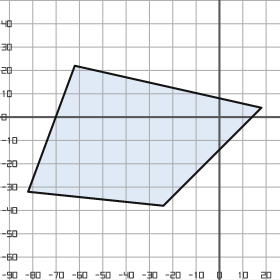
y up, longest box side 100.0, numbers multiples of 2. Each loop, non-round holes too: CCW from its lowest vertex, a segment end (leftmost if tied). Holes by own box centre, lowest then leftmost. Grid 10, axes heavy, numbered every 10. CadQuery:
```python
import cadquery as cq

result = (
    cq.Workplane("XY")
    .moveTo(-24.0, -38.0)
    .lineTo(18.0, 4.0)
    .lineTo(-62.0, 22.0)
    .lineTo(-82.0, -32.0)
    .close()
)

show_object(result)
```